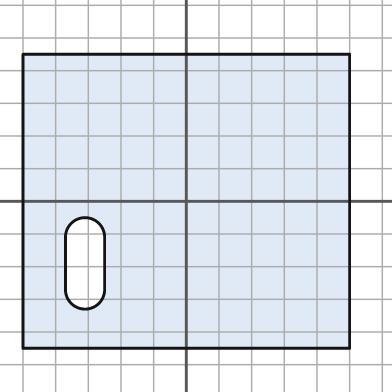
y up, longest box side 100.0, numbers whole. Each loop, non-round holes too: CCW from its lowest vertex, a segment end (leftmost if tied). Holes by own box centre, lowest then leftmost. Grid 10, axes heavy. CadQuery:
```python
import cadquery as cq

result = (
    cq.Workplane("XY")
    .moveTo(-50.0, -45.0)
    .lineTo(50.0, -45.0)
    .lineTo(50.0, 45.0)
    .lineTo(-50.0, 45.0)
    .close()
    .moveTo(-37.0, -27.0)
    .threePointArc((-31.0, -33.0), (-25.0, -27.0))
    .lineTo(-25.0, -11.0)
    .threePointArc((-31.0, -5.0), (-37.0, -11.0))
    .close()
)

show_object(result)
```